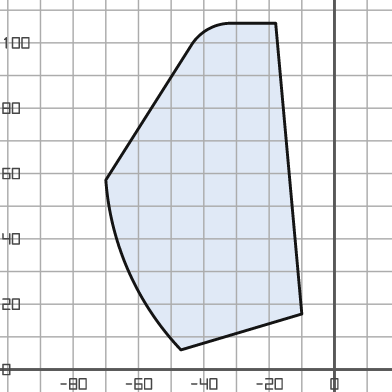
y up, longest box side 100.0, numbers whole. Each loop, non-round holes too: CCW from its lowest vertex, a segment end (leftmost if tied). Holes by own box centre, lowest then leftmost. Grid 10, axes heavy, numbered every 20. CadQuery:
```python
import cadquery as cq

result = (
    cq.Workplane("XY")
    .moveTo(-47.0, 6.0)
    .lineTo(-10.0, 17.0)
    .lineTo(-18.0, 106.0)
    .lineTo(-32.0, 106.0)
    .threePointArc((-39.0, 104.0), (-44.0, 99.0))
    .lineTo(-70.0, 58.0)
    .threePointArc((-63.0, 30.0), (-47.0, 6.0))
    .close()
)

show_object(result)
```